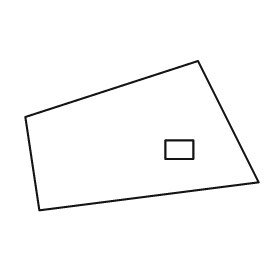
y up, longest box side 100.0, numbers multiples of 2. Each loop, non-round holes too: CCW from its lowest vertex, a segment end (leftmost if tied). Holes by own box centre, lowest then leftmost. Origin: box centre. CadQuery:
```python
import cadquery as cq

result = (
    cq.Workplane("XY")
    .moveTo(-44.0, -32.0)
    .lineTo(50.0, -20.0)
    .lineTo(24.0, 32.0)
    .lineTo(-50.0, 8.0)
    .close()
    .moveTo(10.0, -10.0)
    .lineTo(22.0, -10.0)
    .lineTo(22.0, -2.0)
    .lineTo(10.0, -2.0)
    .close()
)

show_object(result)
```